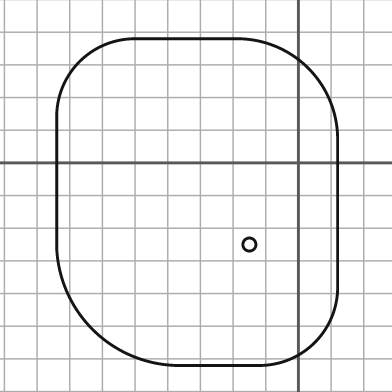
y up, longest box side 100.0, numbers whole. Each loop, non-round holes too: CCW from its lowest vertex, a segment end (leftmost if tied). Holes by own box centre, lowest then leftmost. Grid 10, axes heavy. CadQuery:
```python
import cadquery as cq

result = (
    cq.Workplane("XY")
    .moveTo(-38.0, -62.0)
    .lineTo(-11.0, -62.0)
    .threePointArc((5.0, -55.0), (12.0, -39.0))
    .lineTo(12.0, 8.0)
    .threePointArc((3.0, 29.0), (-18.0, 38.0))
    .lineTo(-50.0, 38.0)
    .threePointArc((-67.0, 31.0), (-74.0, 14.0))
    .lineTo(-74.0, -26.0)
    .threePointArc((-63.0, -51.0), (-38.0, -62.0))
    .close()
    .moveTo(-15.0, -25.0)
    .circle(2.0)
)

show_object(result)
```